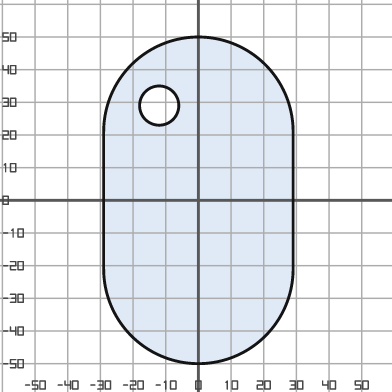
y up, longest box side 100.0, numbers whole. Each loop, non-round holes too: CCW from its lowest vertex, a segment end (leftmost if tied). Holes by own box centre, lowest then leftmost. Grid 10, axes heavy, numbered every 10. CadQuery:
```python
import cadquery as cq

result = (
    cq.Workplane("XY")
    .moveTo(-29.0, -21.0)
    .threePointArc((0.0, -50.0), (29.0, -21.0))
    .lineTo(29.0, 21.0)
    .threePointArc((0.0, 50.0), (-29.0, 21.0))
    .close()
    .moveTo(-12.0, 29.0)
    .circle(6.0)
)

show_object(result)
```